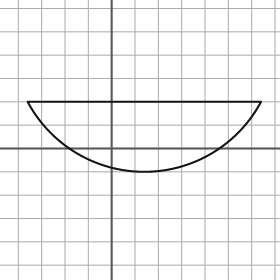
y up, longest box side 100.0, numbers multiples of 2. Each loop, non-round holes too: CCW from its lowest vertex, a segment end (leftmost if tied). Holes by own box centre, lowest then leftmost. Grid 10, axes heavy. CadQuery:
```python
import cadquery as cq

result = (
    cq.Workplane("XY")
    .moveTo(-36.0, 20.0)
    .threePointArc((14.0, -10.0), (64.0, 20.0))
    .close()
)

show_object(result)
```